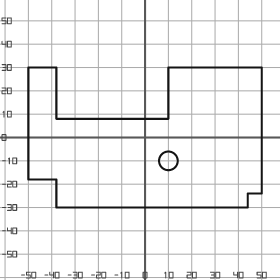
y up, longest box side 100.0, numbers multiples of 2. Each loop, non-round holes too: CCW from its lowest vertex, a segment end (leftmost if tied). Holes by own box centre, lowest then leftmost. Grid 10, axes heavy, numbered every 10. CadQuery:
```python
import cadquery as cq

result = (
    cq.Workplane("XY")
    .moveTo(-38.0, -30.0)
    .lineTo(44.0, -30.0)
    .lineTo(44.0, -24.0)
    .lineTo(50.0, -24.0)
    .lineTo(50.0, 30.0)
    .lineTo(10.0, 30.0)
    .lineTo(10.0, 8.0)
    .lineTo(-38.0, 8.0)
    .lineTo(-38.0, 30.0)
    .lineTo(-50.0, 30.0)
    .lineTo(-50.0, -18.0)
    .lineTo(-38.0, -18.0)
    .close()
    .moveTo(10.0, -10.0)
    .circle(4.0)
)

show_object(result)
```